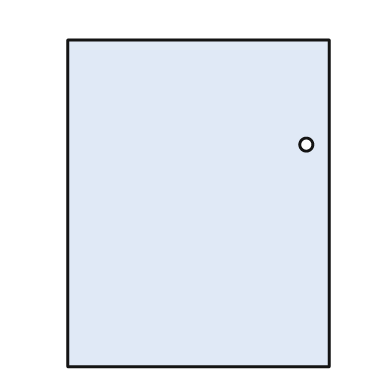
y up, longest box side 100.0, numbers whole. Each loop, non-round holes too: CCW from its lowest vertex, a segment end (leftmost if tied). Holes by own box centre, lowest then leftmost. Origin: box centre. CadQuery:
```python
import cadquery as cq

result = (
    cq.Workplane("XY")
    .moveTo(-40.0, -50.0)
    .lineTo(40.0, -50.0)
    .lineTo(40.0, 50.0)
    .lineTo(-40.0, 50.0)
    .close()
    .moveTo(33.0, 18.0)
    .circle(2.0)
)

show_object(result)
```